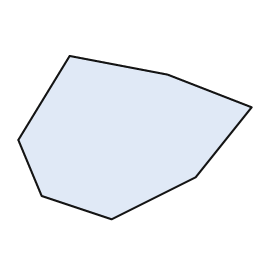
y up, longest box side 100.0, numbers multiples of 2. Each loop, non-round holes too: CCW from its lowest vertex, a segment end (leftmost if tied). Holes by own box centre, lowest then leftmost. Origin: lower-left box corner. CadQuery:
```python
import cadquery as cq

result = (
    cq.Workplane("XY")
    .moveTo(40.0, 0.0)
    .lineTo(76.0, 18.0)
    .lineTo(100.0, 48.0)
    .lineTo(64.0, 62.0)
    .lineTo(22.0, 70.0)
    .lineTo(0.0, 34.0)
    .lineTo(10.0, 10.0)
    .close()
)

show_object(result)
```